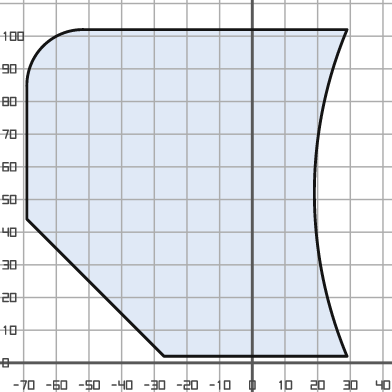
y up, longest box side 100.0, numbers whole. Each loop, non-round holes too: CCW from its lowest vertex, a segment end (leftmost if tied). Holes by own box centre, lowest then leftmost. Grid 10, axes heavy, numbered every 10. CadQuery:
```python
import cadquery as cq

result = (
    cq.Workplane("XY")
    .moveTo(-27.0, 2.0)
    .lineTo(29.0, 2.0)
    .threePointArc((19.0, 52.0), (29.0, 102.0))
    .lineTo(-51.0, 102.0)
    .threePointArc((-64.0, 97.0), (-69.0, 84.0))
    .lineTo(-69.0, 44.0)
    .close()
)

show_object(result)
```